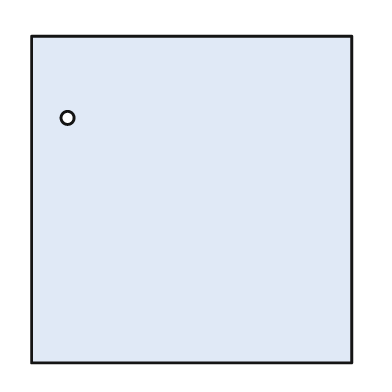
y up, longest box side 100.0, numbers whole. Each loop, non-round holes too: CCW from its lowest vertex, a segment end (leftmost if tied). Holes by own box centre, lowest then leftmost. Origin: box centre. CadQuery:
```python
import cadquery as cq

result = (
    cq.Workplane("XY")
    .moveTo(-49.0, -50.0)
    .lineTo(49.0, -50.0)
    .lineTo(49.0, 50.0)
    .lineTo(-49.0, 50.0)
    .close()
    .moveTo(-38.0, 25.0)
    .circle(2.0)
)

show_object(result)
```